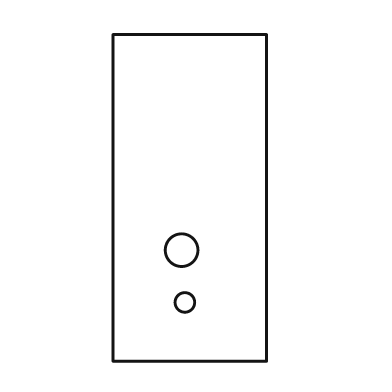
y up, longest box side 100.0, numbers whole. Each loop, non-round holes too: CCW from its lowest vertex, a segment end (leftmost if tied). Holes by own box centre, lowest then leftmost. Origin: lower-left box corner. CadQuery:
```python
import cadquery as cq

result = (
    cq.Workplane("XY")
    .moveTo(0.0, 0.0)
    .lineTo(47.0, 0.0)
    .lineTo(47.0, 100.0)
    .lineTo(0.0, 100.0)
    .close()
    .moveTo(22.0, 18.0)
    .circle(3.0)
    .moveTo(21.0, 34.0)
    .circle(5.0)
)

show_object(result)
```